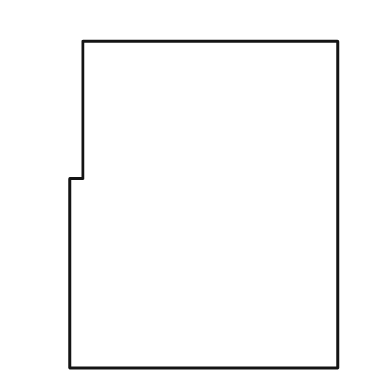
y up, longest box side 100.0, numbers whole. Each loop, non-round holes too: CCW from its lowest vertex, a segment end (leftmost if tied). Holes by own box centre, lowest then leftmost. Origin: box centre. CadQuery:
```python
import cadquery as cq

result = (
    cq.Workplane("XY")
    .moveTo(-41.0, -50.0)
    .lineTo(41.0, -50.0)
    .lineTo(41.0, 50.0)
    .lineTo(-37.0, 50.0)
    .lineTo(-37.0, 8.0)
    .lineTo(-41.0, 8.0)
    .close()
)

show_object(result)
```